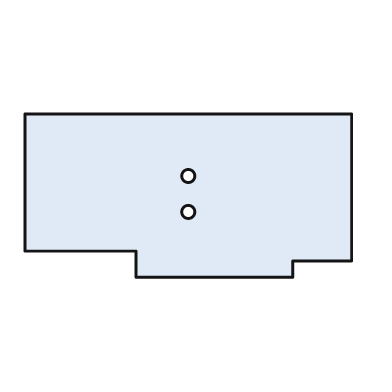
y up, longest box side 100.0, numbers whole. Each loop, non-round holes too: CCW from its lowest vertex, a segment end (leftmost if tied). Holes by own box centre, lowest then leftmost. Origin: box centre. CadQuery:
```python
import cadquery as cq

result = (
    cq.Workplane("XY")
    .moveTo(-16.0, -25.0)
    .lineTo(32.0, -25.0)
    .lineTo(32.0, -20.0)
    .lineTo(50.0, -20.0)
    .lineTo(50.0, 25.0)
    .lineTo(-50.0, 25.0)
    .lineTo(-50.0, -17.0)
    .lineTo(-16.0, -17.0)
    .close()
    .moveTo(0.0, -5.0)
    .circle(2.0)
    .moveTo(0.0, 6.0)
    .circle(2.0)
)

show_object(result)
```